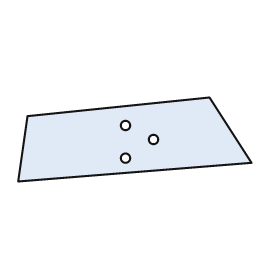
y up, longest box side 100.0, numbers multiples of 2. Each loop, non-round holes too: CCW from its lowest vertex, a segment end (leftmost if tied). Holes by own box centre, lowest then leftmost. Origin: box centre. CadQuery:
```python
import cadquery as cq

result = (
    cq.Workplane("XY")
    .moveTo(-50.0, -18.0)
    .lineTo(50.0, -10.0)
    .lineTo(32.0, 18.0)
    .lineTo(-46.0, 10.0)
    .close()
    .moveTo(-4.0, -8.0)
    .circle(2.0)
    .moveTo(8.0, 0.0)
    .circle(2.0)
    .moveTo(-4.0, 6.0)
    .circle(2.0)
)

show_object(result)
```